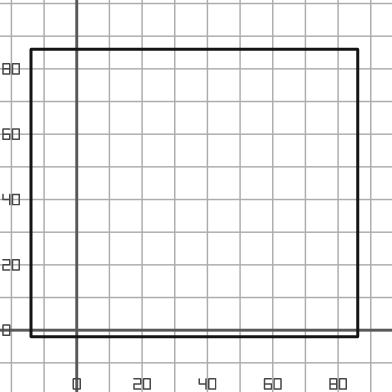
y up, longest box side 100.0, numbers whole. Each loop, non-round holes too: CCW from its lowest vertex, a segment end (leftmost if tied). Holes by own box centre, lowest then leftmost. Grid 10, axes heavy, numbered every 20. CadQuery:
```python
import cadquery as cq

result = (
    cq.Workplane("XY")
    .moveTo(-14.0, -2.0)
    .lineTo(86.0, -2.0)
    .lineTo(86.0, 86.0)
    .lineTo(-14.0, 86.0)
    .close()
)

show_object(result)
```